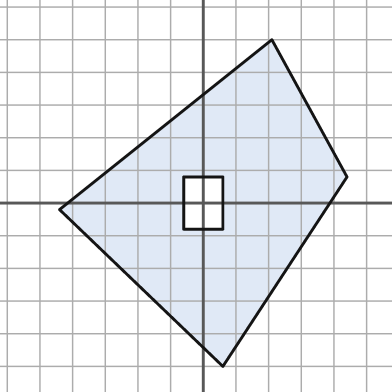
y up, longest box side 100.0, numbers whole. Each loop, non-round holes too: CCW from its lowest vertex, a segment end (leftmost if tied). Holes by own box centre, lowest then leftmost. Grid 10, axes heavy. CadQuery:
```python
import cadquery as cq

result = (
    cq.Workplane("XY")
    .moveTo(6.0, -50.0)
    .lineTo(44.0, 8.0)
    .lineTo(21.0, 50.0)
    .lineTo(-44.0, -2.0)
    .close()
    .moveTo(-6.0, -8.0)
    .lineTo(6.0, -8.0)
    .lineTo(6.0, 8.0)
    .lineTo(-6.0, 8.0)
    .close()
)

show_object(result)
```